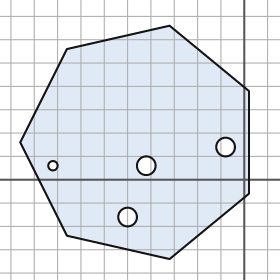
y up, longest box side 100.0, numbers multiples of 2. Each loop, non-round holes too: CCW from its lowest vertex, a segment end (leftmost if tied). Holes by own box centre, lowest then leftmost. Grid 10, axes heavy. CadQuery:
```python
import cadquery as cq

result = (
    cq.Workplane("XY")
    .moveTo(-32.0, -34.0)
    .lineTo(2.0, -6.0)
    .lineTo(2.0, 38.0)
    .lineTo(-32.0, 66.0)
    .lineTo(-76.0, 56.0)
    .lineTo(-96.0, 16.0)
    .lineTo(-76.0, -24.0)
    .close()
    .moveTo(-50.0, -16.0)
    .circle(4.0)
    .moveTo(-82.0, 6.0)
    .circle(2.0)
    .moveTo(-42.0, 6.0)
    .circle(4.0)
    .moveTo(-8.0, 14.0)
    .circle(4.0)
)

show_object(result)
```